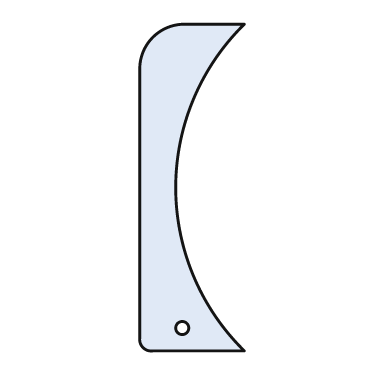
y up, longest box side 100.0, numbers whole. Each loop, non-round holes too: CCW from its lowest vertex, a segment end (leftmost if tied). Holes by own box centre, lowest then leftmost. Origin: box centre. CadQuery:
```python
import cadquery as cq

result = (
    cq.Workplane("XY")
    .moveTo(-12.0, -50.0)
    .lineTo(16.0, -50.0)
    .threePointArc((-5.0, 0.0), (16.0, 50.0))
    .lineTo(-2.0, 50.0)
    .threePointArc((-12.0, 46.0), (-16.0, 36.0))
    .lineTo(-16.0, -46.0)
    .threePointArc((-15.0, -49.0), (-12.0, -50.0))
    .close()
    .moveTo(-3.0, -43.0)
    .circle(2.0)
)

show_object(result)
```